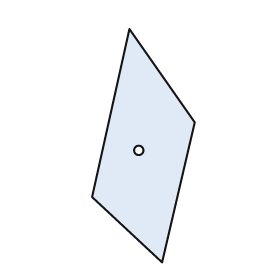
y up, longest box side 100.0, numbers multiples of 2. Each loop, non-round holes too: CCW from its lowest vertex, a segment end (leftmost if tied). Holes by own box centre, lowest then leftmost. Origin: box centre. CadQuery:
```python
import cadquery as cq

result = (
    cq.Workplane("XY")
    .moveTo(8.0, -50.0)
    .lineTo(22.0, 10.0)
    .lineTo(-6.0, 50.0)
    .lineTo(-22.0, -22.0)
    .close()
    .moveTo(-2.0, -2.0)
    .circle(2.0)
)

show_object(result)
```